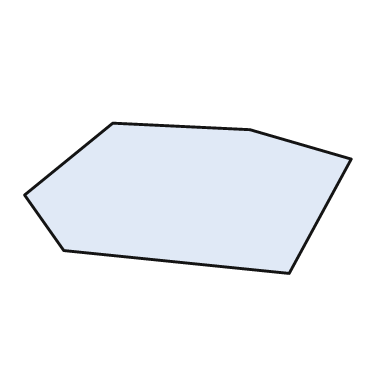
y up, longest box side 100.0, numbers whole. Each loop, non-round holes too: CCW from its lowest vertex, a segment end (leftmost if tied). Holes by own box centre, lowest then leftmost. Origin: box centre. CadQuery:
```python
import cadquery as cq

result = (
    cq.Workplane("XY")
    .moveTo(31.0, -23.0)
    .lineTo(50.0, 12.0)
    .lineTo(19.0, 21.0)
    .lineTo(-23.0, 23.0)
    .lineTo(-50.0, 1.0)
    .lineTo(-38.0, -16.0)
    .close()
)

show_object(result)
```